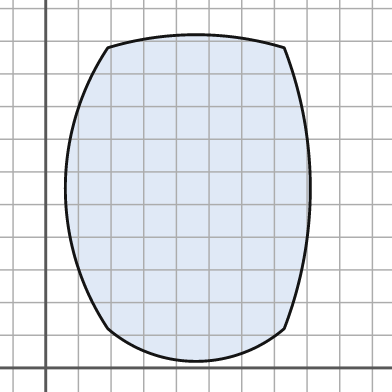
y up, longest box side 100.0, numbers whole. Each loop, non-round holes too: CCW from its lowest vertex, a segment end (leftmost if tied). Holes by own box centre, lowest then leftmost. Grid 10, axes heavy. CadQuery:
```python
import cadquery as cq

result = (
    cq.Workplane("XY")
    .moveTo(19.0, 12.0)
    .threePointArc((46.0, 2.0), (73.0, 12.0))
    .threePointArc((81.0, 55.0), (73.0, 98.0))
    .threePointArc((46.0, 102.0), (19.0, 98.0))
    .threePointArc((6.0, 55.0), (19.0, 12.0))
    .close()
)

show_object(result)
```